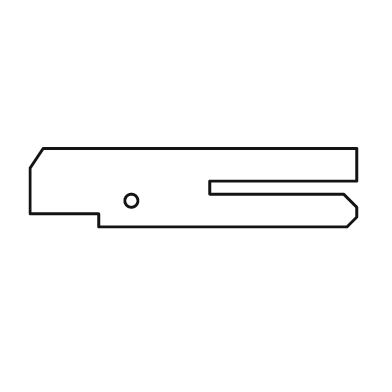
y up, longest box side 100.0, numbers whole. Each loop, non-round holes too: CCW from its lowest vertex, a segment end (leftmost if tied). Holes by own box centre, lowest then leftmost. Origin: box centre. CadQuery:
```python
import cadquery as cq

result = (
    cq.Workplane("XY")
    .moveTo(-29.0, -12.0)
    .lineTo(47.0, -12.0)
    .lineTo(50.0, -9.0)
    .lineTo(50.0, -6.0)
    .lineTo(46.0, -2.0)
    .lineTo(5.0, -2.0)
    .lineTo(5.0, 2.0)
    .lineTo(50.0, 2.0)
    .lineTo(50.0, 12.0)
    .lineTo(-46.0, 12.0)
    .lineTo(-50.0, 6.0)
    .lineTo(-50.0, -8.0)
    .lineTo(-29.0, -8.0)
    .close()
    .moveTo(-19.0, -4.0)
    .circle(2.0)
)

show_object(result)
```